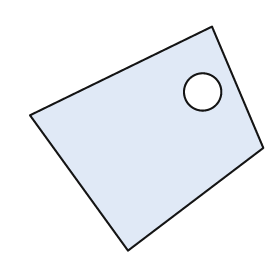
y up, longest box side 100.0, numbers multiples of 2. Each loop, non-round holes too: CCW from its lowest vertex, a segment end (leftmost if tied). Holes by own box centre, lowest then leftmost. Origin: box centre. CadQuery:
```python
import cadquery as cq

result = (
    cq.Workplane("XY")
    .moveTo(-8.0, -48.0)
    .lineTo(50.0, -4.0)
    .lineTo(28.0, 48.0)
    .lineTo(-50.0, 10.0)
    .close()
    .moveTo(24.0, 20.0)
    .circle(8.0)
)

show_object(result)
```